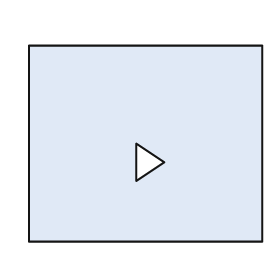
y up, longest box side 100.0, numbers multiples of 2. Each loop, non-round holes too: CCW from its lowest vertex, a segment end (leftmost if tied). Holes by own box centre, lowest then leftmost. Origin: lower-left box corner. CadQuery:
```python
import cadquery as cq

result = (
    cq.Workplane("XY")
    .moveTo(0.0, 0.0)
    .lineTo(100.0, 0.0)
    .lineTo(100.0, 84.0)
    .lineTo(0.0, 84.0)
    .close()
    .moveTo(46.0, 26.0)
    .lineTo(58.0, 34.0)
    .lineTo(46.0, 42.0)
    .close()
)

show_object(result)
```